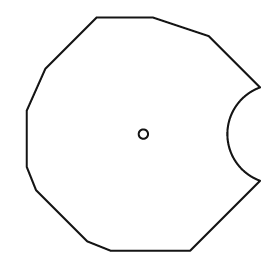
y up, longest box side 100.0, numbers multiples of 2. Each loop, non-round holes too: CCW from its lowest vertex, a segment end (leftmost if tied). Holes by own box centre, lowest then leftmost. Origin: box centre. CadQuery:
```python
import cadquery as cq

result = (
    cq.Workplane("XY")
    .moveTo(-14.0, -50.0)
    .lineTo(20.0, -50.0)
    .lineTo(50.0, -20.0)
    .threePointArc((36.0, 0.0), (50.0, 20.0))
    .lineTo(28.0, 42.0)
    .lineTo(4.0, 50.0)
    .lineTo(-20.0, 50.0)
    .lineTo(-42.0, 28.0)
    .lineTo(-50.0, 10.0)
    .lineTo(-50.0, -14.0)
    .lineTo(-46.0, -24.0)
    .lineTo(-24.0, -46.0)
    .close()
    .moveTo(0.0, 0.0)
    .circle(2.0)
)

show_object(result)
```